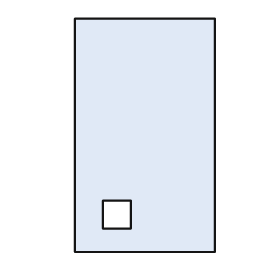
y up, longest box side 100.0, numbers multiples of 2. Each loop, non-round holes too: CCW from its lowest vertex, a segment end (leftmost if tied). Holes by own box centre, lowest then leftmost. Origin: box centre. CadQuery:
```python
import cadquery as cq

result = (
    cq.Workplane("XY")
    .moveTo(-30.0, -50.0)
    .lineTo(30.0, -50.0)
    .lineTo(30.0, 50.0)
    .lineTo(-30.0, 50.0)
    .close()
    .moveTo(-18.0, -40.0)
    .lineTo(-6.0, -40.0)
    .lineTo(-6.0, -28.0)
    .lineTo(-18.0, -28.0)
    .close()
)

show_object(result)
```